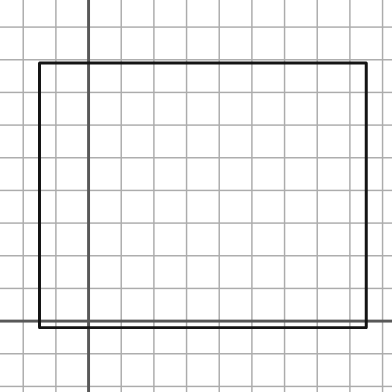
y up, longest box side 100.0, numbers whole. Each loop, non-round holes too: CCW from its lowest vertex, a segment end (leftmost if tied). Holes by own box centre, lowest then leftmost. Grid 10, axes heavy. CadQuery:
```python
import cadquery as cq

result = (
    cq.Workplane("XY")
    .moveTo(-15.0, -2.0)
    .lineTo(85.0, -2.0)
    .lineTo(85.0, 79.0)
    .lineTo(-15.0, 79.0)
    .close()
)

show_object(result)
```